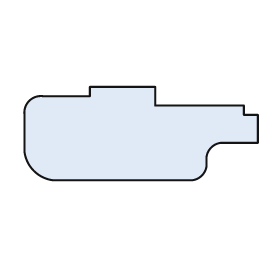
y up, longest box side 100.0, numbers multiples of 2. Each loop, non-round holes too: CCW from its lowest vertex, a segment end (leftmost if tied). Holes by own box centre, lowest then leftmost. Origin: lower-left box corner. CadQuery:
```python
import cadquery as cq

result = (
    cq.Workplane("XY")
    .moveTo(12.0, 0.0)
    .lineTo(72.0, 0.0)
    .threePointArc((76.0, 2.0), (78.0, 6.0))
    .lineTo(78.0, 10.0)
    .threePointArc((80.0, 14.0), (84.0, 16.0))
    .lineTo(100.0, 16.0)
    .lineTo(100.0, 28.0)
    .lineTo(94.0, 28.0)
    .lineTo(94.0, 32.0)
    .lineTo(56.0, 32.0)
    .lineTo(56.0, 40.0)
    .lineTo(28.0, 40.0)
    .lineTo(28.0, 36.0)
    .lineTo(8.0, 36.0)
    .threePointArc((2.0, 34.0), (0.0, 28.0))
    .lineTo(0.0, 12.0)
    .threePointArc((4.0, 4.0), (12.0, 0.0))
    .close()
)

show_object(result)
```